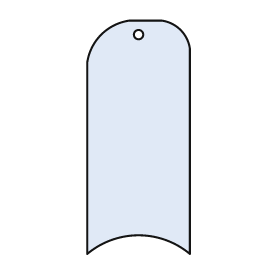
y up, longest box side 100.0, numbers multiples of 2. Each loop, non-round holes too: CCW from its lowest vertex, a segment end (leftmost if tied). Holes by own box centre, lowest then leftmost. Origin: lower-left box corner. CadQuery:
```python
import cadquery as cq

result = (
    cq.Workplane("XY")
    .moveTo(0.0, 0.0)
    .threePointArc((22.0, 8.0), (44.0, 0.0))
    .lineTo(44.0, 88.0)
    .threePointArc((40.0, 96.0), (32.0, 100.0))
    .lineTo(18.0, 100.0)
    .threePointArc((6.0, 94.0), (0.0, 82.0))
    .close()
    .moveTo(22.0, 94.0)
    .circle(2.0)
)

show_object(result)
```